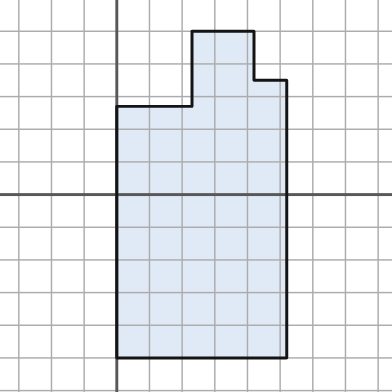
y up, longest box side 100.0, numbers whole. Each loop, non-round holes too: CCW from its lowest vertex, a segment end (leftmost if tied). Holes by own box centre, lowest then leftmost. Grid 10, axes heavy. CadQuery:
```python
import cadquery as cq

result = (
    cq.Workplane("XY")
    .moveTo(0.0, -50.0)
    .lineTo(52.0, -50.0)
    .lineTo(52.0, 35.0)
    .lineTo(42.0, 35.0)
    .lineTo(42.0, 50.0)
    .lineTo(23.0, 50.0)
    .lineTo(23.0, 27.0)
    .lineTo(0.0, 27.0)
    .close()
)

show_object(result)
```